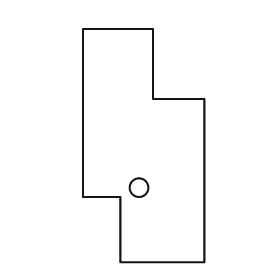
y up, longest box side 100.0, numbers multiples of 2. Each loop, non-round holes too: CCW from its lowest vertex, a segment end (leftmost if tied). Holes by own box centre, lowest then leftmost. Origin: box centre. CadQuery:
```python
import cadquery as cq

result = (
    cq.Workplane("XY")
    .moveTo(-10.0, -50.0)
    .lineTo(26.0, -50.0)
    .lineTo(26.0, 20.0)
    .lineTo(4.0, 20.0)
    .lineTo(4.0, 50.0)
    .lineTo(-26.0, 50.0)
    .lineTo(-26.0, -22.0)
    .lineTo(-10.0, -22.0)
    .close()
    .moveTo(-2.0, -18.0)
    .circle(4.0)
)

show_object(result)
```